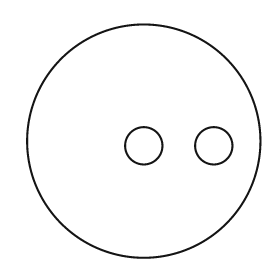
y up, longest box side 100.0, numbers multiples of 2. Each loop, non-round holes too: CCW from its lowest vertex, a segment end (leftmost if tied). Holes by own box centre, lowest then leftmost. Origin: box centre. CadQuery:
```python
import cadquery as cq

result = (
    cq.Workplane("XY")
    .moveTo(0.0, 0.0)
    .circle(50.0)
    .moveTo(0.0, -2.0)
    .circle(8.0)
    .moveTo(30.0, -2.0)
    .circle(8.0)
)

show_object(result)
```